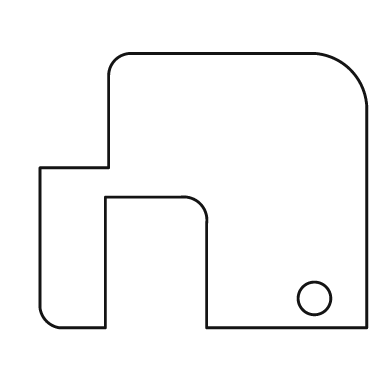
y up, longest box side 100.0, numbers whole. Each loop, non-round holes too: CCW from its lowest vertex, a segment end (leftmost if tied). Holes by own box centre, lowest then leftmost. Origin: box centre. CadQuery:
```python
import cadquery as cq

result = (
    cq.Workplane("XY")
    .moveTo(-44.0, -42.0)
    .lineTo(-30.0, -42.0)
    .lineTo(-30.0, -2.0)
    .lineTo(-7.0, -2.0)
    .threePointArc((-1.0, -4.0), (1.0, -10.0))
    .lineTo(1.0, -42.0)
    .lineTo(50.0, -42.0)
    .lineTo(50.0, 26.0)
    .threePointArc((45.0, 37.0), (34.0, 42.0))
    .lineTo(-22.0, 42.0)
    .threePointArc((-27.0, 40.0), (-29.0, 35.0))
    .lineTo(-29.0, 7.0)
    .lineTo(-50.0, 7.0)
    .lineTo(-50.0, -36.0)
    .threePointArc((-48.0, -40.0), (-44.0, -42.0))
    .close()
    .moveTo(34.0, -33.0)
    .circle(5.0)
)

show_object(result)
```